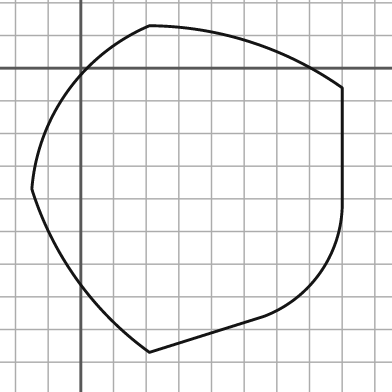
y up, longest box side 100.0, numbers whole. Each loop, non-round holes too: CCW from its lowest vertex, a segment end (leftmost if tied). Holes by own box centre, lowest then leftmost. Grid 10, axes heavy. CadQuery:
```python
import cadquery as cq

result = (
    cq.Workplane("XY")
    .moveTo(21.0, -87.0)
    .lineTo(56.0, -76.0)
    .threePointArc((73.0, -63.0), (80.0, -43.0))
    .lineTo(80.0, -6.0)
    .threePointArc((52.0, 8.0), (21.0, 13.0))
    .threePointArc((-4.0, -7.0), (-15.0, -37.0))
    .threePointArc((-1.0, -65.0), (21.0, -87.0))
    .close()
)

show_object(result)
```